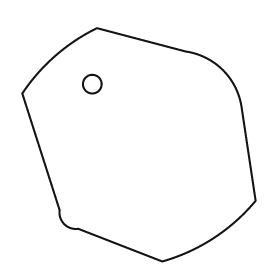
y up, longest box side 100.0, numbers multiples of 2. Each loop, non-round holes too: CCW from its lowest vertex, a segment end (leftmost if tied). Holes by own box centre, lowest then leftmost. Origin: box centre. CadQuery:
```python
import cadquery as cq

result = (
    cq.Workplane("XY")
    .moveTo(10.0, -50.0)
    .threePointArc((32.0, -40.0), (50.0, -24.0))
    .lineTo(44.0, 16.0)
    .threePointArc((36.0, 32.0), (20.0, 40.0))
    .lineTo(-18.0, 50.0)
    .threePointArc((-36.0, 38.0), (-50.0, 22.0))
    .lineTo(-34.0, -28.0)
    .threePointArc((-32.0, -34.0), (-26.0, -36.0))
    .close()
    .moveTo(-20.0, 26.0)
    .circle(4.0)
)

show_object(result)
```